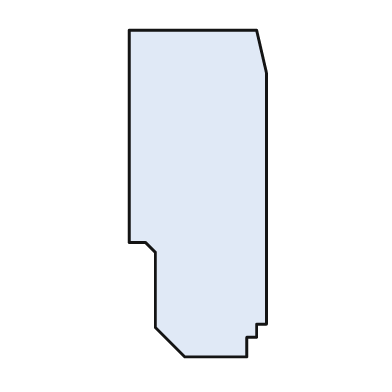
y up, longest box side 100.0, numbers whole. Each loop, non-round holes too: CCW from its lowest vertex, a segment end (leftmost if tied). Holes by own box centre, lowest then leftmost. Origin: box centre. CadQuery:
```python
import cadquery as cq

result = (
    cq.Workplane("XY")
    .moveTo(-4.0, -50.0)
    .lineTo(15.0, -50.0)
    .lineTo(15.0, -44.0)
    .lineTo(18.0, -44.0)
    .lineTo(18.0, -40.0)
    .lineTo(21.0, -40.0)
    .lineTo(21.0, 37.0)
    .lineTo(18.0, 50.0)
    .lineTo(-21.0, 50.0)
    .lineTo(-21.0, -15.0)
    .lineTo(-16.0, -15.0)
    .lineTo(-13.0, -18.0)
    .lineTo(-13.0, -41.0)
    .close()
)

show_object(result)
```